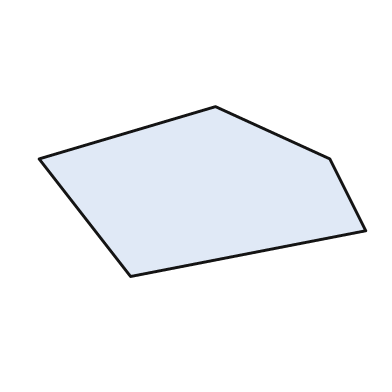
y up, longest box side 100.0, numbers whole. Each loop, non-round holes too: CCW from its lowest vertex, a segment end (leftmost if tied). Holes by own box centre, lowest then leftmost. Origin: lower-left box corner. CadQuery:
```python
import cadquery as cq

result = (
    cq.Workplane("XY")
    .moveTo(28.0, 0.0)
    .lineTo(100.0, 14.0)
    .lineTo(89.0, 36.0)
    .lineTo(54.0, 52.0)
    .lineTo(0.0, 36.0)
    .close()
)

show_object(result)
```